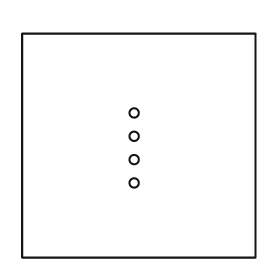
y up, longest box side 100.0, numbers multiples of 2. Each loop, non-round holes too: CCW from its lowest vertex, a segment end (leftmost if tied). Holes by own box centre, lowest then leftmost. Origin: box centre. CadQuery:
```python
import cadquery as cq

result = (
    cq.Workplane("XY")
    .moveTo(-50.0, -48.0)
    .lineTo(50.0, -48.0)
    .lineTo(50.0, 48.0)
    .lineTo(-50.0, 48.0)
    .close()
    .moveTo(-2.0, -16.0)
    .circle(2.0)
    .moveTo(-2.0, -6.0)
    .circle(2.0)
    .moveTo(-2.0, 4.0)
    .circle(2.0)
    .moveTo(-2.0, 14.0)
    .circle(2.0)
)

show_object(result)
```